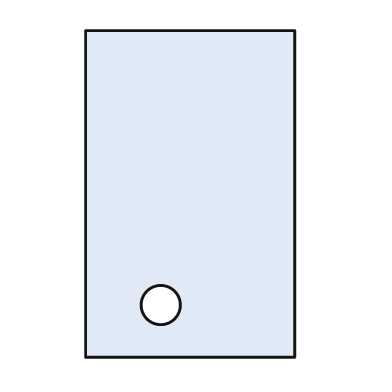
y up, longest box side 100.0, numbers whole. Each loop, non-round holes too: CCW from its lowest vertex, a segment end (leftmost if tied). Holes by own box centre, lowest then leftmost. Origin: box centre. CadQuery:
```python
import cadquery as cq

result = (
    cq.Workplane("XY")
    .moveTo(-32.0, -50.0)
    .lineTo(32.0, -50.0)
    .lineTo(32.0, 50.0)
    .lineTo(-32.0, 50.0)
    .close()
    .moveTo(-9.0, -34.0)
    .circle(6.0)
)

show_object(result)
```